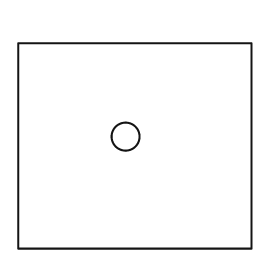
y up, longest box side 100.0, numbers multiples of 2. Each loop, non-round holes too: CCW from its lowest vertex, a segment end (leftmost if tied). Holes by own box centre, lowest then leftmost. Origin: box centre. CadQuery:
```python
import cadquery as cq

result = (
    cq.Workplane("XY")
    .moveTo(-50.0, -44.0)
    .lineTo(50.0, -44.0)
    .lineTo(50.0, 44.0)
    .lineTo(-50.0, 44.0)
    .close()
    .moveTo(-4.0, 4.0)
    .circle(6.0)
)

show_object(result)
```